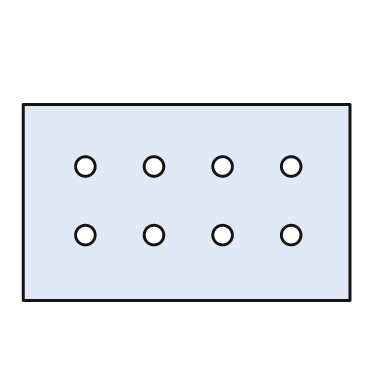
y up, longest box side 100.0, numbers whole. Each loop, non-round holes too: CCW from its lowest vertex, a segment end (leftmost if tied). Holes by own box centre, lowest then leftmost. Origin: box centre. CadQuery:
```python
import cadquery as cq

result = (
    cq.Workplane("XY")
    .moveTo(-50.0, -30.0)
    .lineTo(50.0, -30.0)
    .lineTo(50.0, 30.0)
    .lineTo(-50.0, 30.0)
    .close()
    .moveTo(-31.0, -10.0)
    .circle(3.0)
    .moveTo(-10.0, -10.0)
    .circle(3.0)
    .moveTo(11.0, -10.0)
    .circle(3.0)
    .moveTo(32.0, -10.0)
    .circle(3.0)
    .moveTo(-31.0, 11.0)
    .circle(3.0)
    .moveTo(-10.0, 11.0)
    .circle(3.0)
    .moveTo(11.0, 11.0)
    .circle(3.0)
    .moveTo(32.0, 11.0)
    .circle(3.0)
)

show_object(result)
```